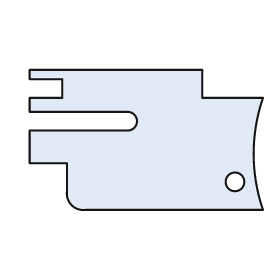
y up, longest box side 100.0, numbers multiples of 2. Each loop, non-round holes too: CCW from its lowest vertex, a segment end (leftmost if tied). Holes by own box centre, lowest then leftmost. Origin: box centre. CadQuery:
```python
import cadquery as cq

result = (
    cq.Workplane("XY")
    .moveTo(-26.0, -30.0)
    .lineTo(50.0, -30.0)
    .threePointArc((46.0, -6.0), (50.0, 18.0))
    .lineTo(24.0, 18.0)
    .lineTo(24.0, 30.0)
    .lineTo(-50.0, 30.0)
    .lineTo(-50.0, 26.0)
    .lineTo(-36.0, 26.0)
    .lineTo(-36.0, 18.0)
    .lineTo(-50.0, 18.0)
    .lineTo(-50.0, 12.0)
    .lineTo(-8.0, 12.0)
    .threePointArc((-4.0, 8.0), (-8.0, 4.0))
    .lineTo(-50.0, 4.0)
    .lineTo(-50.0, -10.0)
    .lineTo(-34.0, -10.0)
    .lineTo(-34.0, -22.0)
    .threePointArc((-32.0, -28.0), (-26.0, -30.0))
    .close()
    .moveTo(38.0, -18.0)
    .circle(4.0)
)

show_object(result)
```